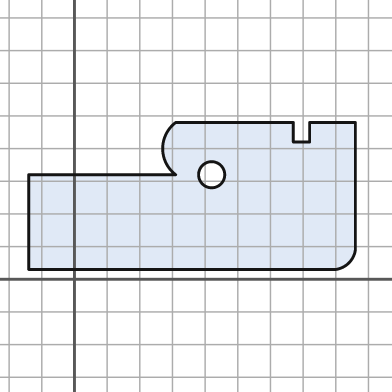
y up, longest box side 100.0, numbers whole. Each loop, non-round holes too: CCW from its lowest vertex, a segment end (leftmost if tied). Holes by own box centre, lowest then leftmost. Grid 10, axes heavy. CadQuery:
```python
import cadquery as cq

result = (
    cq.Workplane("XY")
    .moveTo(-14.0, 3.0)
    .lineTo(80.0, 3.0)
    .threePointArc((84.0, 5.0), (86.0, 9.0))
    .lineTo(86.0, 48.0)
    .lineTo(72.0, 48.0)
    .lineTo(72.0, 42.0)
    .lineTo(67.0, 42.0)
    .lineTo(67.0, 48.0)
    .lineTo(31.0, 48.0)
    .threePointArc((27.0, 40.0), (31.0, 32.0))
    .lineTo(-14.0, 32.0)
    .close()
    .moveTo(42.0, 32.0)
    .circle(4.0)
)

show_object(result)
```